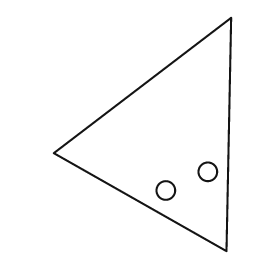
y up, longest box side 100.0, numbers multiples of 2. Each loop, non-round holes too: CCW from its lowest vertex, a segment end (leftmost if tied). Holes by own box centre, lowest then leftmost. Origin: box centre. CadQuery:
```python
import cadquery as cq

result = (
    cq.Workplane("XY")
    .moveTo(36.0, -50.0)
    .lineTo(38.0, 50.0)
    .lineTo(-38.0, -8.0)
    .close()
    .moveTo(10.0, -24.0)
    .circle(4.0)
    .moveTo(28.0, -16.0)
    .circle(4.0)
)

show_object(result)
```